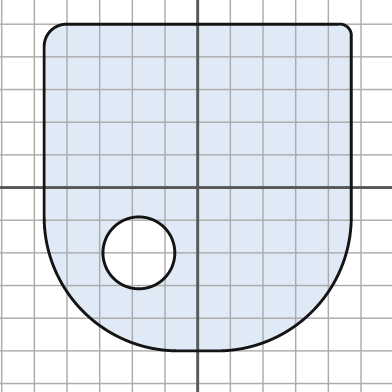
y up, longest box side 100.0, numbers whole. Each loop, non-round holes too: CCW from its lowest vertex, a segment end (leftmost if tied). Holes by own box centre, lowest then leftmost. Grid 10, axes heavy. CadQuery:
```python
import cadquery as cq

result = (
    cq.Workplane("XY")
    .moveTo(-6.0, -50.0)
    .lineTo(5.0, -50.0)
    .threePointArc((35.0, -38.0), (47.0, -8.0))
    .lineTo(47.0, 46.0)
    .threePointArc((46.0, 49.0), (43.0, 50.0))
    .lineTo(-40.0, 50.0)
    .threePointArc((-45.0, 48.0), (-47.0, 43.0))
    .lineTo(-47.0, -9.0)
    .threePointArc((-35.0, -38.0), (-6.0, -50.0))
    .close()
    .moveTo(-18.0, -20.0)
    .circle(11.0)
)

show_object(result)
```